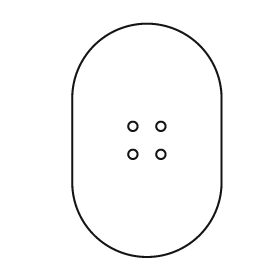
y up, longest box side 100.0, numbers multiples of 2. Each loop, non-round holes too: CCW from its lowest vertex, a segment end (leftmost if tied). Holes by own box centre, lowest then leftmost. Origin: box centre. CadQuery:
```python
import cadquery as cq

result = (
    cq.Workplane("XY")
    .moveTo(-32.0, -18.0)
    .threePointArc((0.0, -50.0), (32.0, -18.0))
    .lineTo(32.0, 18.0)
    .threePointArc((0.0, 50.0), (-32.0, 18.0))
    .close()
    .moveTo(-6.0, -6.0)
    .circle(2.0)
    .moveTo(6.0, -6.0)
    .circle(2.0)
    .moveTo(-6.0, 6.0)
    .circle(2.0)
    .moveTo(6.0, 6.0)
    .circle(2.0)
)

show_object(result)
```